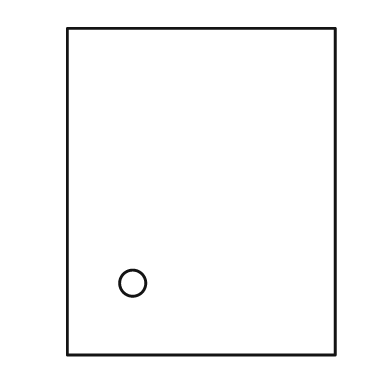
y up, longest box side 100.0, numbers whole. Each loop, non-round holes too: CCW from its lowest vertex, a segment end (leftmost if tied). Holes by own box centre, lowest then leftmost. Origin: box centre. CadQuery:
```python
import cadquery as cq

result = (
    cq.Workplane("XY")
    .moveTo(-41.0, -50.0)
    .lineTo(41.0, -50.0)
    .lineTo(41.0, 50.0)
    .lineTo(-41.0, 50.0)
    .close()
    .moveTo(-21.0, -28.0)
    .circle(4.0)
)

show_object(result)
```